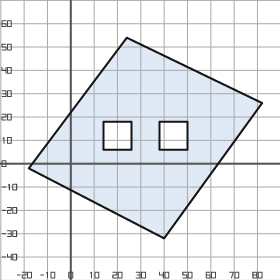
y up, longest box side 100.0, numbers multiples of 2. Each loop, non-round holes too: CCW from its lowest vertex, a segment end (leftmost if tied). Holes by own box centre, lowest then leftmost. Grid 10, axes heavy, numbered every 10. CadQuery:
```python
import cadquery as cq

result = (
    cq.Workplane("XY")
    .moveTo(40.0, -32.0)
    .lineTo(82.0, 26.0)
    .lineTo(24.0, 54.0)
    .lineTo(-18.0, -2.0)
    .close()
    .moveTo(14.0, 6.0)
    .lineTo(26.0, 6.0)
    .lineTo(26.0, 18.0)
    .lineTo(14.0, 18.0)
    .close()
    .moveTo(38.0, 6.0)
    .lineTo(50.0, 6.0)
    .lineTo(50.0, 18.0)
    .lineTo(38.0, 18.0)
    .close()
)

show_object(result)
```